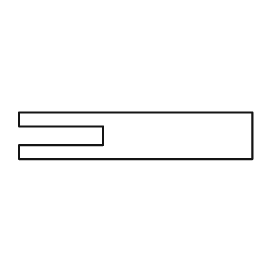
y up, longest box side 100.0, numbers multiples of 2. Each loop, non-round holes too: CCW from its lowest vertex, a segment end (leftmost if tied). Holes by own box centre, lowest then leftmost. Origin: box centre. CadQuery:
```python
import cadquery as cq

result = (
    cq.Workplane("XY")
    .moveTo(-50.0, -10.0)
    .lineTo(50.0, -10.0)
    .lineTo(50.0, 10.0)
    .lineTo(-50.0, 10.0)
    .lineTo(-50.0, 4.0)
    .lineTo(-14.0, 4.0)
    .lineTo(-14.0, -4.0)
    .lineTo(-50.0, -4.0)
    .close()
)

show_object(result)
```